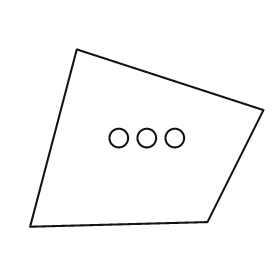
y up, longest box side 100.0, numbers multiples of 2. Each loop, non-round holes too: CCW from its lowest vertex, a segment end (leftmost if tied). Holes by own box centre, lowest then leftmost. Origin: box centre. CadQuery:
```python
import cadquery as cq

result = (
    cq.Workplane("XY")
    .moveTo(-50.0, -38.0)
    .lineTo(26.0, -36.0)
    .lineTo(50.0, 12.0)
    .lineTo(-30.0, 38.0)
    .close()
    .moveTo(-12.0, 0.0)
    .circle(4.0)
    .moveTo(0.0, 0.0)
    .circle(4.0)
    .moveTo(12.0, 0.0)
    .circle(4.0)
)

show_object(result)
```